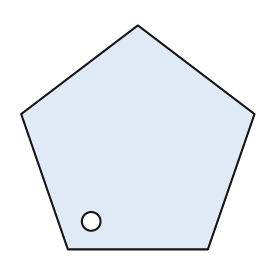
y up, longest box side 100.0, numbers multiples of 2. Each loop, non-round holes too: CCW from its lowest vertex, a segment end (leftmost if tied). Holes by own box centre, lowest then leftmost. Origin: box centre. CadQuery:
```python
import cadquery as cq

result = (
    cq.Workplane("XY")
    .moveTo(-30.0, -48.0)
    .lineTo(30.0, -48.0)
    .lineTo(50.0, 10.0)
    .lineTo(0.0, 48.0)
    .lineTo(-50.0, 10.0)
    .close()
    .moveTo(-20.0, -36.0)
    .circle(4.0)
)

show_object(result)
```